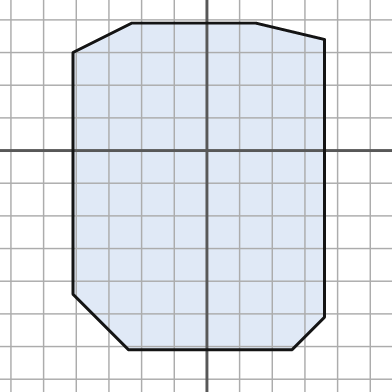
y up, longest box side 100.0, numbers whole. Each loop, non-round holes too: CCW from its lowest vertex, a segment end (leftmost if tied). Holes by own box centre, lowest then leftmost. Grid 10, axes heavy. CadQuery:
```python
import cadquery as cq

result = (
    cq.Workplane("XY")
    .moveTo(-24.0, -61.0)
    .lineTo(26.0, -61.0)
    .lineTo(36.0, -51.0)
    .lineTo(36.0, 34.0)
    .lineTo(15.0, 39.0)
    .lineTo(-23.0, 39.0)
    .lineTo(-41.0, 30.0)
    .lineTo(-41.0, -44.0)
    .close()
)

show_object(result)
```